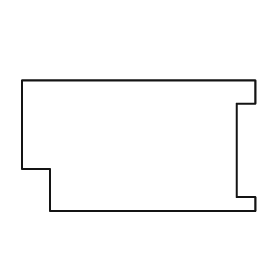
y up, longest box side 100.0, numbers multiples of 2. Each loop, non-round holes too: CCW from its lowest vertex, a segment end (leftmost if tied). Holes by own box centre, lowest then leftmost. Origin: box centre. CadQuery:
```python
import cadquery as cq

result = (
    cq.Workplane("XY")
    .moveTo(-38.0, -28.0)
    .lineTo(50.0, -28.0)
    .lineTo(50.0, -22.0)
    .lineTo(42.0, -22.0)
    .lineTo(42.0, 18.0)
    .lineTo(50.0, 18.0)
    .lineTo(50.0, 28.0)
    .lineTo(-50.0, 28.0)
    .lineTo(-50.0, -10.0)
    .lineTo(-38.0, -10.0)
    .close()
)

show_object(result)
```